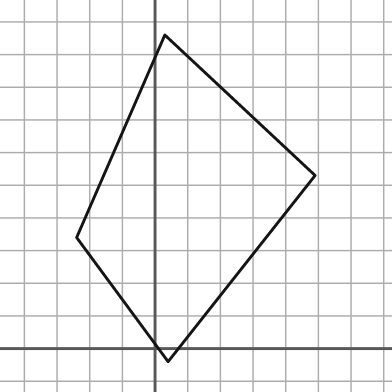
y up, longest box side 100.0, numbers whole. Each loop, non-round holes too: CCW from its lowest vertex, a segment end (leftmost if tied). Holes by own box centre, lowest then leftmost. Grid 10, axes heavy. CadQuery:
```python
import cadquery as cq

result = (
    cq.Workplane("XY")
    .moveTo(4.0, -4.0)
    .lineTo(49.0, 53.0)
    .lineTo(3.0, 96.0)
    .lineTo(-24.0, 34.0)
    .close()
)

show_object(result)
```